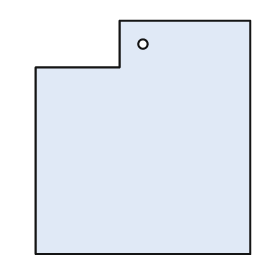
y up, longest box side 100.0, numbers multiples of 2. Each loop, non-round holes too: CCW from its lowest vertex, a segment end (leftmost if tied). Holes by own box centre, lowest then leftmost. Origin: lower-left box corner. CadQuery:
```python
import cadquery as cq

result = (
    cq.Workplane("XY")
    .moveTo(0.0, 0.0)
    .lineTo(92.0, 0.0)
    .lineTo(92.0, 100.0)
    .lineTo(36.0, 100.0)
    .lineTo(36.0, 80.0)
    .lineTo(0.0, 80.0)
    .close()
    .moveTo(46.0, 90.0)
    .circle(2.0)
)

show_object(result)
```